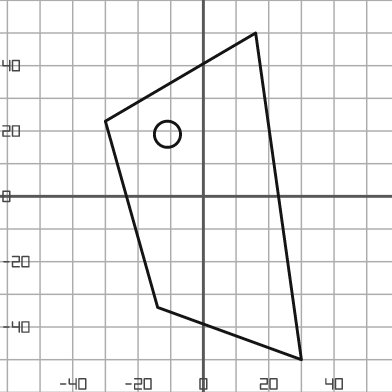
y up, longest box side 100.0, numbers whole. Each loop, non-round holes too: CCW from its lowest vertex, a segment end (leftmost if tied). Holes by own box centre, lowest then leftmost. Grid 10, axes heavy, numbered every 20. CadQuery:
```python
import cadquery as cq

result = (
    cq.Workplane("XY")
    .moveTo(30.0, -50.0)
    .lineTo(16.0, 50.0)
    .lineTo(-30.0, 23.0)
    .lineTo(-14.0, -34.0)
    .close()
    .moveTo(-11.0, 19.0)
    .circle(4.0)
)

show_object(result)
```